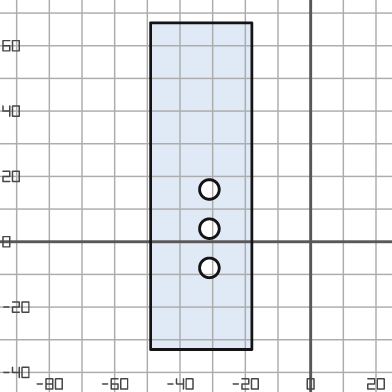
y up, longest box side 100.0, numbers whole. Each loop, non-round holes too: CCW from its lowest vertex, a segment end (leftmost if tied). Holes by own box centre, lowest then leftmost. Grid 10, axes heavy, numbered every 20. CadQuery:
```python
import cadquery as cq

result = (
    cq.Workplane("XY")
    .moveTo(-49.0, -33.0)
    .lineTo(-18.0, -33.0)
    .lineTo(-18.0, 67.0)
    .lineTo(-49.0, 67.0)
    .close()
    .moveTo(-31.0, -8.0)
    .circle(3.0)
    .moveTo(-31.0, 4.0)
    .circle(3.0)
    .moveTo(-31.0, 16.0)
    .circle(3.0)
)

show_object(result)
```